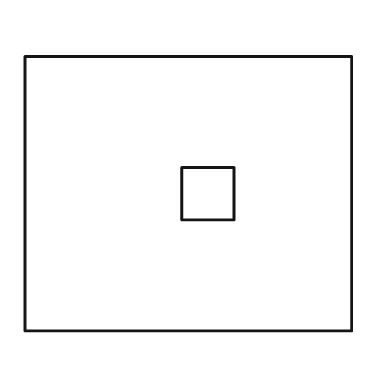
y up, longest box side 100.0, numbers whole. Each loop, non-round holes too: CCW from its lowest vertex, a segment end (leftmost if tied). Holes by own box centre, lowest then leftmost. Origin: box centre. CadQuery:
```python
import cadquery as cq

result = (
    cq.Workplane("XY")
    .moveTo(-50.0, -42.0)
    .lineTo(50.0, -42.0)
    .lineTo(50.0, 42.0)
    .lineTo(-50.0, 42.0)
    .close()
    .moveTo(-2.0, -8.0)
    .lineTo(14.0, -8.0)
    .lineTo(14.0, 8.0)
    .lineTo(-2.0, 8.0)
    .close()
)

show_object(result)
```